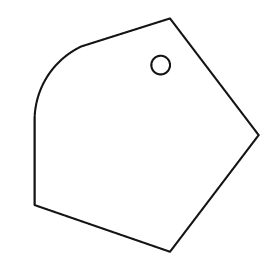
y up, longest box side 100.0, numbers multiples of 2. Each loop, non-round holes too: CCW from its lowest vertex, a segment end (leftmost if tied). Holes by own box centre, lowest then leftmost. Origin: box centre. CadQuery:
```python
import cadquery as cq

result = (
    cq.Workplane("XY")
    .moveTo(10.0, -50.0)
    .lineTo(48.0, 0.0)
    .lineTo(10.0, 50.0)
    .lineTo(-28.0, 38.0)
    .threePointArc((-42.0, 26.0), (-48.0, 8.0))
    .lineTo(-48.0, -30.0)
    .close()
    .moveTo(6.0, 30.0)
    .circle(4.0)
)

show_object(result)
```